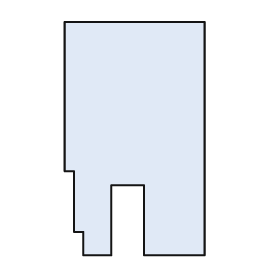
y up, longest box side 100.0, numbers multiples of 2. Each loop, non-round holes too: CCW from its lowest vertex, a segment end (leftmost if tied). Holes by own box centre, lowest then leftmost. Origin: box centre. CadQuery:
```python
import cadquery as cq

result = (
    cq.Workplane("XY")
    .moveTo(-22.0, -50.0)
    .lineTo(-10.0, -50.0)
    .lineTo(-10.0, -20.0)
    .lineTo(4.0, -20.0)
    .lineTo(4.0, -50.0)
    .lineTo(30.0, -50.0)
    .lineTo(30.0, 50.0)
    .lineTo(-30.0, 50.0)
    .lineTo(-30.0, -14.0)
    .lineTo(-26.0, -14.0)
    .lineTo(-26.0, -40.0)
    .lineTo(-22.0, -40.0)
    .close()
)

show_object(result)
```